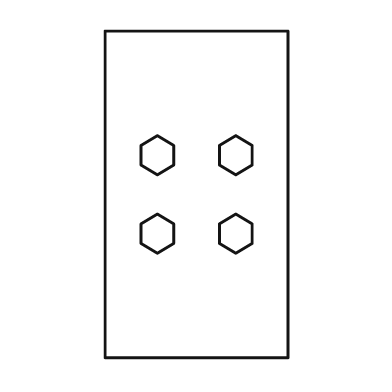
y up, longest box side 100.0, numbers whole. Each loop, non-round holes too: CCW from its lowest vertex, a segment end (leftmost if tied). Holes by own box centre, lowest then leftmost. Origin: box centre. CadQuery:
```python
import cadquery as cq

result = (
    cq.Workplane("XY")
    .moveTo(-28.0, -50.0)
    .lineTo(28.0, -50.0)
    .lineTo(28.0, 50.0)
    .lineTo(-28.0, 50.0)
    .close()
    .moveTo(-12.0, -18.0)
    .lineTo(-7.0, -15.0)
    .lineTo(-7.0, -9.0)
    .lineTo(-12.0, -6.0)
    .lineTo(-17.0, -9.0)
    .lineTo(-17.0, -15.0)
    .close()
    .moveTo(12.0, -18.0)
    .lineTo(17.0, -15.0)
    .lineTo(17.0, -9.0)
    .lineTo(12.0, -6.0)
    .lineTo(7.0, -9.0)
    .lineTo(7.0, -15.0)
    .close()
    .moveTo(-12.0, 6.0)
    .lineTo(-7.0, 9.0)
    .lineTo(-7.0, 15.0)
    .lineTo(-12.0, 18.0)
    .lineTo(-17.0, 15.0)
    .lineTo(-17.0, 9.0)
    .close()
    .moveTo(12.0, 6.0)
    .lineTo(17.0, 9.0)
    .lineTo(17.0, 15.0)
    .lineTo(12.0, 18.0)
    .lineTo(7.0, 15.0)
    .lineTo(7.0, 9.0)
    .close()
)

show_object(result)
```